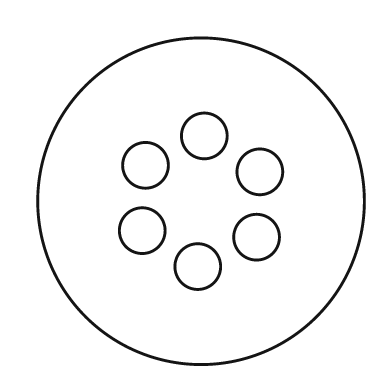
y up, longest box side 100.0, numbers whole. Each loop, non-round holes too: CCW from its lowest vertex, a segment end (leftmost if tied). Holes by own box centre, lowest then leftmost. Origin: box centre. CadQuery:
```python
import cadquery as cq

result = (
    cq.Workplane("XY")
    .moveTo(0.0, 0.0)
    .circle(50.0)
    .moveTo(-1.0, -20.0)
    .circle(7.0)
    .moveTo(17.0, -11.0)
    .circle(7.0)
    .moveTo(-18.0, -9.0)
    .circle(7.0)
    .moveTo(18.0, 9.0)
    .circle(7.0)
    .moveTo(-17.0, 11.0)
    .circle(7.0)
    .moveTo(1.0, 20.0)
    .circle(7.0)
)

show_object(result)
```